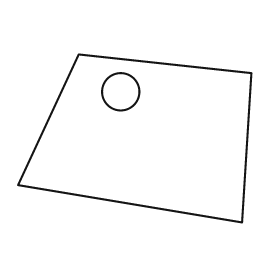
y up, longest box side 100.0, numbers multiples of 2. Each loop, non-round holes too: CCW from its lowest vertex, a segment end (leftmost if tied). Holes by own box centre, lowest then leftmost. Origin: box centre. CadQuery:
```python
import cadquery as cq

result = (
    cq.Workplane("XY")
    .moveTo(46.0, -36.0)
    .lineTo(50.0, 28.0)
    .lineTo(-24.0, 36.0)
    .lineTo(-50.0, -20.0)
    .close()
    .moveTo(-6.0, 20.0)
    .circle(8.0)
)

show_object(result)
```